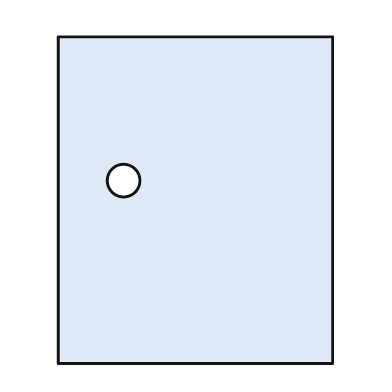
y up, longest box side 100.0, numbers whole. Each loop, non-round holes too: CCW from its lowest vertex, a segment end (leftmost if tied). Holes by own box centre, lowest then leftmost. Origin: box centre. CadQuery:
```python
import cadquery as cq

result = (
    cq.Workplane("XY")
    .moveTo(-42.0, -50.0)
    .lineTo(42.0, -50.0)
    .lineTo(42.0, 50.0)
    .lineTo(-42.0, 50.0)
    .close()
    .moveTo(-22.0, 6.0)
    .circle(5.0)
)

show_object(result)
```